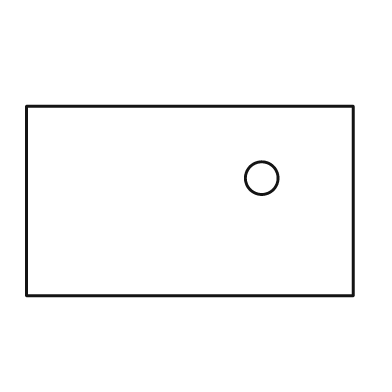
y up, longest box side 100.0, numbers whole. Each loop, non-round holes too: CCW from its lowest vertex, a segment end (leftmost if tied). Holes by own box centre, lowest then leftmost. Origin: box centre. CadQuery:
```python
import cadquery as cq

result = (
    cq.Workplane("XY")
    .moveTo(-50.0, -29.0)
    .lineTo(50.0, -29.0)
    .lineTo(50.0, 29.0)
    .lineTo(-50.0, 29.0)
    .close()
    .moveTo(22.0, 7.0)
    .circle(5.0)
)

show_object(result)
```